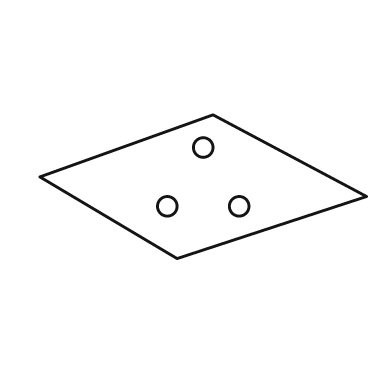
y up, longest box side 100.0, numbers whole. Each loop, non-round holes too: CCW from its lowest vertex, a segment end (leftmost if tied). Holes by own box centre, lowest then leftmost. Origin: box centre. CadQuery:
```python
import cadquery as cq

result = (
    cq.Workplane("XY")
    .moveTo(-8.0, -22.0)
    .lineTo(50.0, -3.0)
    .lineTo(3.0, 22.0)
    .lineTo(-50.0, 3.0)
    .close()
    .moveTo(-11.0, -6.0)
    .circle(3.0)
    .moveTo(11.0, -6.0)
    .circle(3.0)
    .moveTo(0.0, 12.0)
    .circle(3.0)
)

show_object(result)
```